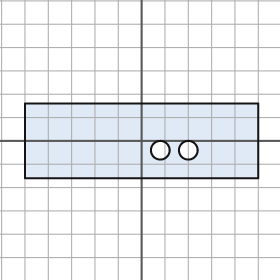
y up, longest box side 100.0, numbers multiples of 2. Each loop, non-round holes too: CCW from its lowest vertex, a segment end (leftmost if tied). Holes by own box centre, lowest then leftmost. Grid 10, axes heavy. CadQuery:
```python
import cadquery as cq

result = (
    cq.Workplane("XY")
    .moveTo(-50.0, -16.0)
    .lineTo(50.0, -16.0)
    .lineTo(50.0, 16.0)
    .lineTo(-50.0, 16.0)
    .close()
    .moveTo(8.0, -4.0)
    .circle(4.0)
    .moveTo(20.0, -4.0)
    .circle(4.0)
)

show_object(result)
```